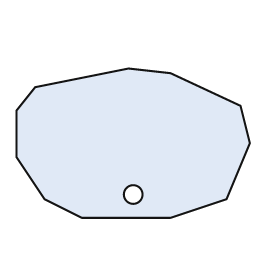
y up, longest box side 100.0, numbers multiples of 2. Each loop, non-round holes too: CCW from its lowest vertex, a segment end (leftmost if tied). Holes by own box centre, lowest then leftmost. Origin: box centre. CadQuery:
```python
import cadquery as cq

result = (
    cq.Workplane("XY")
    .moveTo(-22.0, -32.0)
    .lineTo(16.0, -32.0)
    .lineTo(40.0, -24.0)
    .lineTo(50.0, 0.0)
    .lineTo(46.0, 16.0)
    .lineTo(16.0, 30.0)
    .lineTo(-2.0, 32.0)
    .lineTo(-42.0, 24.0)
    .lineTo(-50.0, 14.0)
    .lineTo(-50.0, -6.0)
    .lineTo(-38.0, -24.0)
    .close()
    .moveTo(0.0, -22.0)
    .circle(4.0)
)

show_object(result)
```